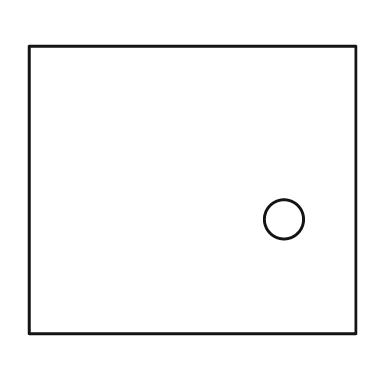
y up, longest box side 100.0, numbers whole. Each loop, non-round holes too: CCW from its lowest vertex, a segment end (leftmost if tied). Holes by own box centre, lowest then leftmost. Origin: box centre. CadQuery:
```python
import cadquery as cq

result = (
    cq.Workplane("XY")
    .moveTo(-50.0, -44.0)
    .lineTo(50.0, -44.0)
    .lineTo(50.0, 44.0)
    .lineTo(-50.0, 44.0)
    .close()
    .moveTo(28.0, -9.0)
    .circle(6.0)
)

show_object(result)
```